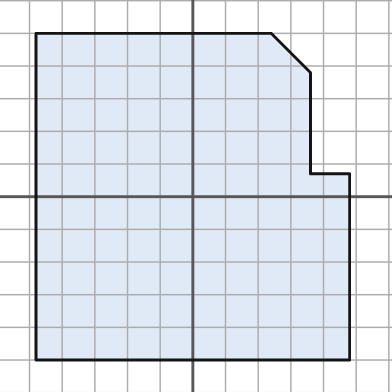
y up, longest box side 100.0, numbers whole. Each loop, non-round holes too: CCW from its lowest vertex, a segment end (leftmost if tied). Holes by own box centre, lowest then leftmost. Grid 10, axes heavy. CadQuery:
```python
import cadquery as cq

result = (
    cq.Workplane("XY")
    .moveTo(-48.0, -50.0)
    .lineTo(48.0, -50.0)
    .lineTo(48.0, 7.0)
    .lineTo(36.0, 7.0)
    .lineTo(36.0, 38.0)
    .lineTo(24.0, 50.0)
    .lineTo(-48.0, 50.0)
    .close()
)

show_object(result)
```